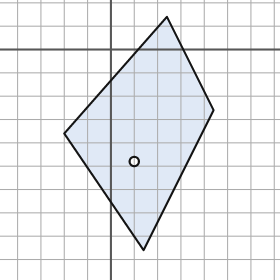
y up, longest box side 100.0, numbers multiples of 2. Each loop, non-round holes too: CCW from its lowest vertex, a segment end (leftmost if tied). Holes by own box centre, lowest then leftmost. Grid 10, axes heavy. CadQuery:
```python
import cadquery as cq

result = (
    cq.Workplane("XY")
    .moveTo(14.0, -86.0)
    .lineTo(44.0, -26.0)
    .lineTo(24.0, 14.0)
    .lineTo(-20.0, -36.0)
    .close()
    .moveTo(10.0, -48.0)
    .circle(2.0)
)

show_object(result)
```